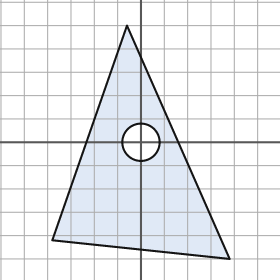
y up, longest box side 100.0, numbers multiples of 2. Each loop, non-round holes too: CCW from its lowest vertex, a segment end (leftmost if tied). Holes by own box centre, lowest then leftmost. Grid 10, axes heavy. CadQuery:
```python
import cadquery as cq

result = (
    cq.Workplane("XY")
    .moveTo(38.0, -50.0)
    .lineTo(-6.0, 50.0)
    .lineTo(-38.0, -42.0)
    .close()
    .moveTo(0.0, 0.0)
    .circle(8.0)
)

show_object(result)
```